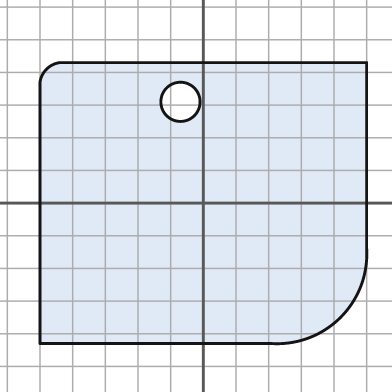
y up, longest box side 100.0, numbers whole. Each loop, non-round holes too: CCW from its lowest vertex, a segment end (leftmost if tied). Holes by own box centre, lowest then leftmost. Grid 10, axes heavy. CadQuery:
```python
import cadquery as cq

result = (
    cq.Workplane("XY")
    .moveTo(-50.0, -43.0)
    .lineTo(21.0, -43.0)
    .threePointArc((42.0, -35.0), (50.0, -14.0))
    .lineTo(50.0, 43.0)
    .lineTo(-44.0, 43.0)
    .threePointArc((-48.0, 41.0), (-50.0, 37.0))
    .close()
    .moveTo(-7.0, 31.0)
    .circle(6.0)
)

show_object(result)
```